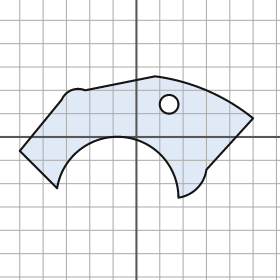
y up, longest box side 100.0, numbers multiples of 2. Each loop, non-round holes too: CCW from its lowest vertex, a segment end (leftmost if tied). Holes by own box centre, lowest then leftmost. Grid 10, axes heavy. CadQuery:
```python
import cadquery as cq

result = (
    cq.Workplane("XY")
    .moveTo(18.0, -26.0)
    .threePointArc((26.0, -22.0), (30.0, -14.0))
    .lineTo(50.0, 8.0)
    .threePointArc((30.0, 20.0), (8.0, 26.0))
    .lineTo(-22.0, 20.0)
    .threePointArc((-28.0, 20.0), (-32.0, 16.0))
    .lineTo(-50.0, -6.0)
    .lineTo(-34.0, -22.0)
    .threePointArc((-6.0, 0.0), (18.0, -26.0))
    .close()
    .moveTo(14.0, 14.0)
    .circle(4.0)
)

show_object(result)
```